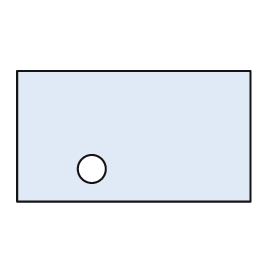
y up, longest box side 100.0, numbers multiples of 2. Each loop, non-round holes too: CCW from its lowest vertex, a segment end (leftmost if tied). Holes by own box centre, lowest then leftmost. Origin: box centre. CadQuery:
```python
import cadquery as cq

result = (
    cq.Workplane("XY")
    .moveTo(-50.0, -28.0)
    .lineTo(50.0, -28.0)
    .lineTo(50.0, 28.0)
    .lineTo(-50.0, 28.0)
    .close()
    .moveTo(-18.0, -14.0)
    .circle(6.0)
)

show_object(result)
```